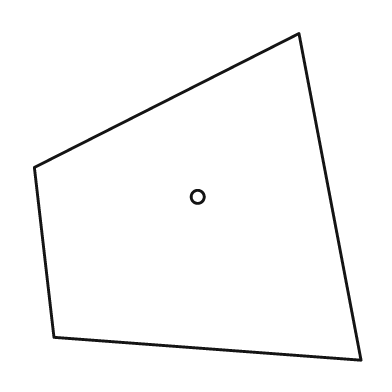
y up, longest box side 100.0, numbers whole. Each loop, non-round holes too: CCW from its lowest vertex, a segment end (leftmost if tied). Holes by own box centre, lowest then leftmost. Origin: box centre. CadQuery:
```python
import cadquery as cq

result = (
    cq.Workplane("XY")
    .moveTo(50.0, -50.0)
    .lineTo(31.0, 50.0)
    .lineTo(-50.0, 9.0)
    .lineTo(-44.0, -43.0)
    .close()
    .moveTo(0.0, 0.0)
    .circle(2.0)
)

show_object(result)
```